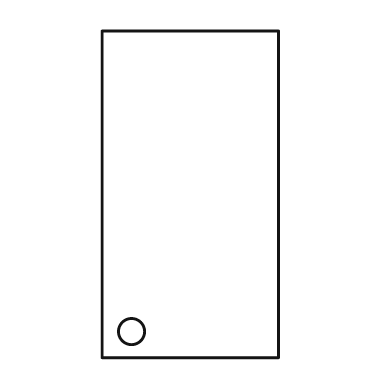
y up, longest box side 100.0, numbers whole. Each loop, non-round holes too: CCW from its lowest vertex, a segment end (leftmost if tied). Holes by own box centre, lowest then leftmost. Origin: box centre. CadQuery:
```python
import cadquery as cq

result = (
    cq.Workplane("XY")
    .moveTo(-27.0, -50.0)
    .lineTo(27.0, -50.0)
    .lineTo(27.0, 50.0)
    .lineTo(-27.0, 50.0)
    .close()
    .moveTo(-18.0, -42.0)
    .circle(4.0)
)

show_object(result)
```